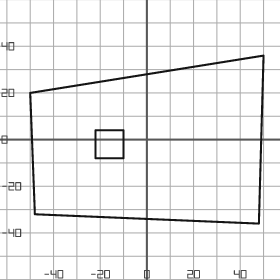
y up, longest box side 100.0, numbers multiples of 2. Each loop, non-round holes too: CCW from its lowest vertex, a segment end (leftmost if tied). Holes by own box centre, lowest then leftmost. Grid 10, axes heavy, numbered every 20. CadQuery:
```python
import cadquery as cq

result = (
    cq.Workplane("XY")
    .moveTo(48.0, -36.0)
    .lineTo(50.0, 36.0)
    .lineTo(-50.0, 20.0)
    .lineTo(-48.0, -32.0)
    .close()
    .moveTo(-22.0, -8.0)
    .lineTo(-10.0, -8.0)
    .lineTo(-10.0, 4.0)
    .lineTo(-22.0, 4.0)
    .close()
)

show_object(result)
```